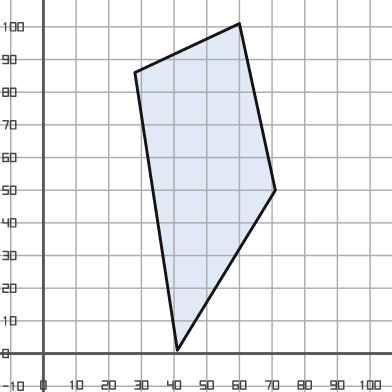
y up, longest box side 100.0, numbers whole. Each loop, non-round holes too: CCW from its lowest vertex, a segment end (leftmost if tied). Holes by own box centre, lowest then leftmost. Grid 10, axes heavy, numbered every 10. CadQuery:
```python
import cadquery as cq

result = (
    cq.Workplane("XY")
    .moveTo(41.0, 1.0)
    .lineTo(71.0, 50.0)
    .lineTo(60.0, 101.0)
    .lineTo(28.0, 86.0)
    .close()
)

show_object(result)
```